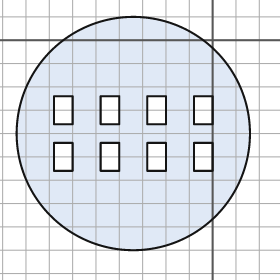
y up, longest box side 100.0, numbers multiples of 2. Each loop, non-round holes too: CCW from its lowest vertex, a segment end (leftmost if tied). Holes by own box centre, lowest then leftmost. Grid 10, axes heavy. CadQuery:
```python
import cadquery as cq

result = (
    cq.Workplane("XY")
    .moveTo(-34.0, -40.0)
    .circle(50.0)
    .moveTo(-68.0, -56.0)
    .lineTo(-60.0, -56.0)
    .lineTo(-60.0, -44.0)
    .lineTo(-68.0, -44.0)
    .close()
    .moveTo(-48.0, -56.0)
    .lineTo(-40.0, -56.0)
    .lineTo(-40.0, -44.0)
    .lineTo(-48.0, -44.0)
    .close()
    .moveTo(-28.0, -56.0)
    .lineTo(-20.0, -56.0)
    .lineTo(-20.0, -44.0)
    .lineTo(-28.0, -44.0)
    .close()
    .moveTo(-8.0, -56.0)
    .lineTo(0.0, -56.0)
    .lineTo(0.0, -44.0)
    .lineTo(-8.0, -44.0)
    .close()
    .moveTo(-68.0, -36.0)
    .lineTo(-60.0, -36.0)
    .lineTo(-60.0, -24.0)
    .lineTo(-68.0, -24.0)
    .close()
    .moveTo(-48.0, -36.0)
    .lineTo(-40.0, -36.0)
    .lineTo(-40.0, -24.0)
    .lineTo(-48.0, -24.0)
    .close()
    .moveTo(-28.0, -36.0)
    .lineTo(-20.0, -36.0)
    .lineTo(-20.0, -24.0)
    .lineTo(-28.0, -24.0)
    .close()
    .moveTo(-8.0, -36.0)
    .lineTo(0.0, -36.0)
    .lineTo(0.0, -24.0)
    .lineTo(-8.0, -24.0)
    .close()
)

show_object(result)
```